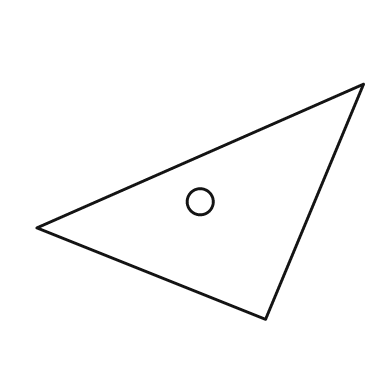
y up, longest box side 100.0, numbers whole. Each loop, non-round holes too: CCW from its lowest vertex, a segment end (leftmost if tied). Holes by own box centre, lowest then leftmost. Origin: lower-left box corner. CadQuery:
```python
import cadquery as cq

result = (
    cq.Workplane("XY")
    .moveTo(70.0, 0.0)
    .lineTo(100.0, 72.0)
    .lineTo(0.0, 28.0)
    .close()
    .moveTo(50.0, 36.0)
    .circle(4.0)
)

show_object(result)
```